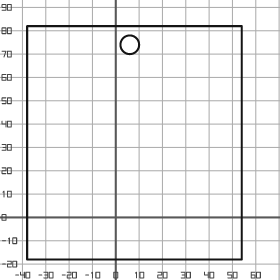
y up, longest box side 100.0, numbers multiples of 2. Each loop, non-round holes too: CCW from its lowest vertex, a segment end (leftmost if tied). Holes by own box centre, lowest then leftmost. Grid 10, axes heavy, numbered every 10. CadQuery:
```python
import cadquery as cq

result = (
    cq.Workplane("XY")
    .moveTo(-38.0, -18.0)
    .lineTo(54.0, -18.0)
    .lineTo(54.0, 82.0)
    .lineTo(-38.0, 82.0)
    .close()
    .moveTo(6.0, 74.0)
    .circle(4.0)
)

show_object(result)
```